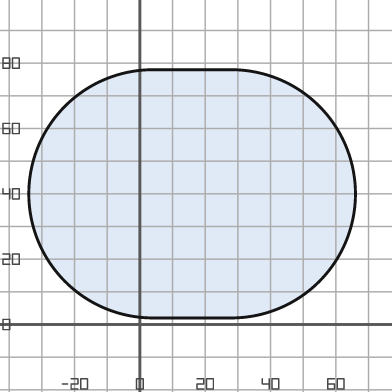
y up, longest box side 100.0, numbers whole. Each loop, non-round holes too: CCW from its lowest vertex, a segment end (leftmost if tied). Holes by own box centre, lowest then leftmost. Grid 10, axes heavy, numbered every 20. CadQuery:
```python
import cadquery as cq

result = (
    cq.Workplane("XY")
    .moveTo(4.0, 2.0)
    .lineTo(28.0, 2.0)
    .threePointArc((66.0, 40.0), (28.0, 78.0))
    .lineTo(4.0, 78.0)
    .threePointArc((-34.0, 40.0), (4.0, 2.0))
    .close()
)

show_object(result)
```